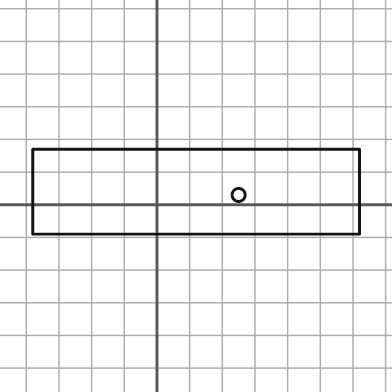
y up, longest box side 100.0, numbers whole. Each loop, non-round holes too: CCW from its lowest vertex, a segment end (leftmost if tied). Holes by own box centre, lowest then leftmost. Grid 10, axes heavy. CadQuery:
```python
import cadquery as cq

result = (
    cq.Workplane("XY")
    .moveTo(-38.0, -9.0)
    .lineTo(62.0, -9.0)
    .lineTo(62.0, 17.0)
    .lineTo(-38.0, 17.0)
    .close()
    .moveTo(25.0, 3.0)
    .circle(2.0)
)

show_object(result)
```